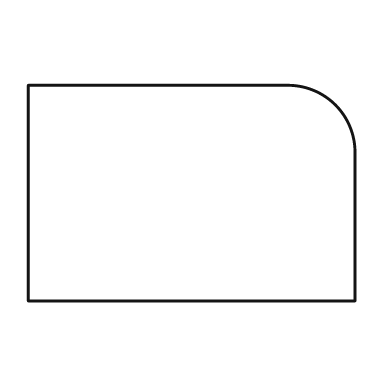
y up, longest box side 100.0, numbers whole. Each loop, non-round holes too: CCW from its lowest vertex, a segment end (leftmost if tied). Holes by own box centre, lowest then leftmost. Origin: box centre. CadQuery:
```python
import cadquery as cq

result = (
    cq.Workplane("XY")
    .moveTo(-50.0, -33.0)
    .lineTo(50.0, -33.0)
    .lineTo(50.0, 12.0)
    .threePointArc((44.0, 27.0), (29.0, 33.0))
    .lineTo(-50.0, 33.0)
    .close()
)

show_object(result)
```